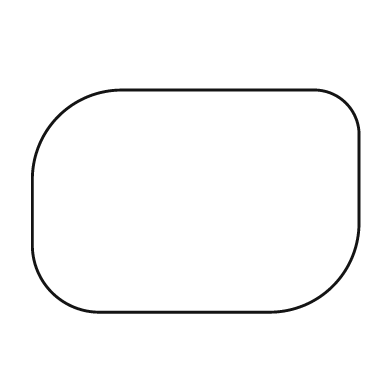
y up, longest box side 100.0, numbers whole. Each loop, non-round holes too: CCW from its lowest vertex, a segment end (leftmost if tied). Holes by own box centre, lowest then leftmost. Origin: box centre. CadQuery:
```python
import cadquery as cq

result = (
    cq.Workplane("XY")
    .moveTo(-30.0, -34.0)
    .lineTo(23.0, -34.0)
    .threePointArc((42.0, -26.0), (50.0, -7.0))
    .lineTo(50.0, 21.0)
    .threePointArc((46.0, 30.0), (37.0, 34.0))
    .lineTo(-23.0, 34.0)
    .threePointArc((-42.0, 26.0), (-50.0, 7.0))
    .lineTo(-50.0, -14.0)
    .threePointArc((-44.0, -28.0), (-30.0, -34.0))
    .close()
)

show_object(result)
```